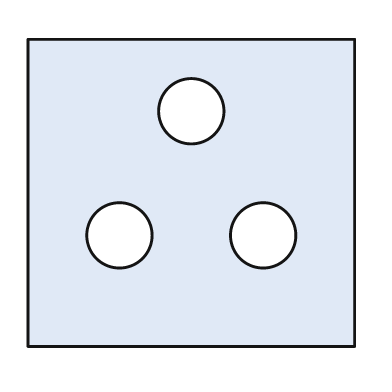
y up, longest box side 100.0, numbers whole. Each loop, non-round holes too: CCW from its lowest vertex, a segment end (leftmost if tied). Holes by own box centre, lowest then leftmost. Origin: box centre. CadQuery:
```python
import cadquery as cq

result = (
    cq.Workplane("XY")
    .moveTo(-50.0, -47.0)
    .lineTo(50.0, -47.0)
    .lineTo(50.0, 47.0)
    .lineTo(-50.0, 47.0)
    .close()
    .moveTo(-22.0, -13.0)
    .circle(10.0)
    .moveTo(22.0, -13.0)
    .circle(10.0)
    .moveTo(0.0, 25.0)
    .circle(10.0)
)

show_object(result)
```